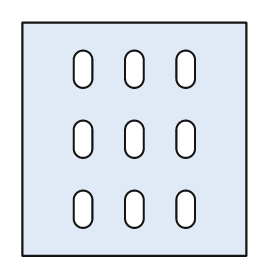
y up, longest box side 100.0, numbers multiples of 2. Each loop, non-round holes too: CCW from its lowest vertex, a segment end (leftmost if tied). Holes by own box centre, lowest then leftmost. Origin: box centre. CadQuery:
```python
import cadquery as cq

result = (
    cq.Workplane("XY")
    .moveTo(-48.0, -50.0)
    .lineTo(48.0, -50.0)
    .lineTo(48.0, 50.0)
    .lineTo(-48.0, 50.0)
    .close()
    .moveTo(-26.0, -34.0)
    .threePointArc((-22.0, -38.0), (-18.0, -34.0))
    .lineTo(-18.0, -26.0)
    .threePointArc((-22.0, -22.0), (-26.0, -26.0))
    .close()
    .moveTo(-4.0, -34.0)
    .threePointArc((0.0, -38.0), (4.0, -34.0))
    .lineTo(4.0, -26.0)
    .threePointArc((0.0, -22.0), (-4.0, -26.0))
    .close()
    .moveTo(18.0, -34.0)
    .threePointArc((22.0, -38.0), (26.0, -34.0))
    .lineTo(26.0, -26.0)
    .threePointArc((22.0, -22.0), (18.0, -26.0))
    .close()
    .moveTo(-26.0, -4.0)
    .threePointArc((-22.0, -8.0), (-18.0, -4.0))
    .lineTo(-18.0, 4.0)
    .threePointArc((-22.0, 8.0), (-26.0, 4.0))
    .close()
    .moveTo(-4.0, -4.0)
    .threePointArc((0.0, -8.0), (4.0, -4.0))
    .lineTo(4.0, 4.0)
    .threePointArc((0.0, 8.0), (-4.0, 4.0))
    .close()
    .moveTo(18.0, -4.0)
    .threePointArc((22.0, -8.0), (26.0, -4.0))
    .lineTo(26.0, 4.0)
    .threePointArc((22.0, 8.0), (18.0, 4.0))
    .close()
    .moveTo(-26.0, 26.0)
    .threePointArc((-22.0, 22.0), (-18.0, 26.0))
    .lineTo(-18.0, 34.0)
    .threePointArc((-22.0, 38.0), (-26.0, 34.0))
    .close()
    .moveTo(-4.0, 26.0)
    .threePointArc((0.0, 22.0), (4.0, 26.0))
    .lineTo(4.0, 34.0)
    .threePointArc((0.0, 38.0), (-4.0, 34.0))
    .close()
    .moveTo(18.0, 26.0)
    .threePointArc((22.0, 22.0), (26.0, 26.0))
    .lineTo(26.0, 34.0)
    .threePointArc((22.0, 38.0), (18.0, 34.0))
    .close()
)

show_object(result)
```